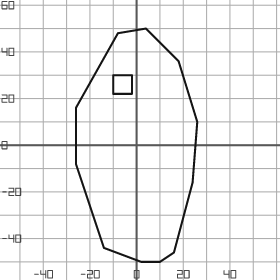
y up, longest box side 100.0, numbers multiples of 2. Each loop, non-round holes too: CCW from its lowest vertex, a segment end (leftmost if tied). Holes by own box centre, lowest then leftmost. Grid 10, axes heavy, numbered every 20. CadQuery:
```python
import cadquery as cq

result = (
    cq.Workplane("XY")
    .moveTo(2.0, -50.0)
    .lineTo(10.0, -50.0)
    .lineTo(16.0, -46.0)
    .lineTo(24.0, -16.0)
    .lineTo(26.0, 10.0)
    .lineTo(18.0, 36.0)
    .lineTo(4.0, 50.0)
    .lineTo(-8.0, 48.0)
    .lineTo(-26.0, 16.0)
    .lineTo(-26.0, -8.0)
    .lineTo(-14.0, -44.0)
    .close()
    .moveTo(-10.0, 22.0)
    .lineTo(-2.0, 22.0)
    .lineTo(-2.0, 30.0)
    .lineTo(-10.0, 30.0)
    .close()
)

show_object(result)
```